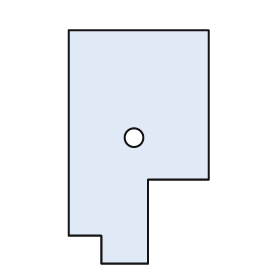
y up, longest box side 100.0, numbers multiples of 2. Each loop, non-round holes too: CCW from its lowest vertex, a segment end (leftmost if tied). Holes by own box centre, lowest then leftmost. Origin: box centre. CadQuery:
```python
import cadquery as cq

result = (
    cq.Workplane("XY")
    .moveTo(-16.0, -50.0)
    .lineTo(4.0, -50.0)
    .lineTo(4.0, -14.0)
    .lineTo(30.0, -14.0)
    .lineTo(30.0, 50.0)
    .lineTo(-30.0, 50.0)
    .lineTo(-30.0, -38.0)
    .lineTo(-16.0, -38.0)
    .close()
    .moveTo(-2.0, 4.0)
    .circle(4.0)
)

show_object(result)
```